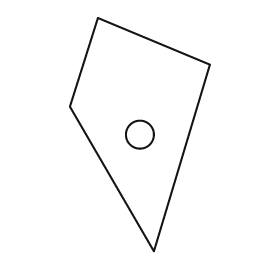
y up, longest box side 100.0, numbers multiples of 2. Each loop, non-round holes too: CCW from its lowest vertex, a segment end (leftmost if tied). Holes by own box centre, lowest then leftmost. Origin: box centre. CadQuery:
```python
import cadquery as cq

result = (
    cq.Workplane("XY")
    .moveTo(6.0, -50.0)
    .lineTo(30.0, 30.0)
    .lineTo(-18.0, 50.0)
    .lineTo(-30.0, 12.0)
    .close()
    .moveTo(0.0, 0.0)
    .circle(6.0)
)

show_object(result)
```